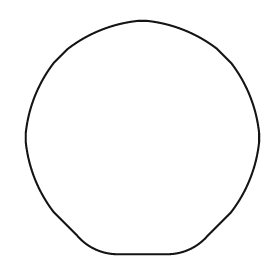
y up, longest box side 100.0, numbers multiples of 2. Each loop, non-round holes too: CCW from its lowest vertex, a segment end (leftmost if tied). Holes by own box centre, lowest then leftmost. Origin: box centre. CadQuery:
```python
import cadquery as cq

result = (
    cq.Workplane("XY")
    .moveTo(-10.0, -50.0)
    .lineTo(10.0, -50.0)
    .threePointArc((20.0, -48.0), (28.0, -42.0))
    .lineTo(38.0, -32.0)
    .threePointArc((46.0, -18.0), (50.0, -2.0))
    .lineTo(50.0, 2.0)
    .threePointArc((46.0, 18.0), (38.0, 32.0))
    .lineTo(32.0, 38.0)
    .threePointArc((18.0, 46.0), (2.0, 50.0))
    .lineTo(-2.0, 50.0)
    .threePointArc((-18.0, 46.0), (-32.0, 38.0))
    .lineTo(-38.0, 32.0)
    .threePointArc((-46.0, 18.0), (-50.0, 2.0))
    .lineTo(-50.0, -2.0)
    .threePointArc((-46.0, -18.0), (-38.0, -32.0))
    .lineTo(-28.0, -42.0)
    .threePointArc((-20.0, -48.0), (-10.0, -50.0))
    .close()
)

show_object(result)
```